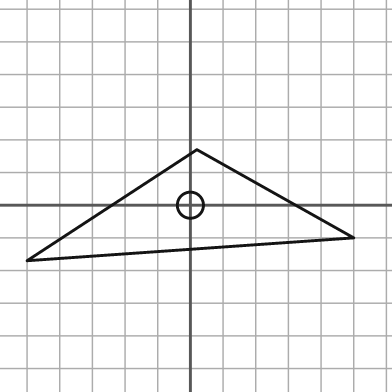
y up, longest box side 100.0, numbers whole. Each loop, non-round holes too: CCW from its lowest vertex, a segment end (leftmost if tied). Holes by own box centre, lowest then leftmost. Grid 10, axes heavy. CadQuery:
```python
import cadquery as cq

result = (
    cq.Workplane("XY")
    .moveTo(-50.0, -17.0)
    .lineTo(50.0, -10.0)
    .lineTo(2.0, 17.0)
    .close()
    .moveTo(0.0, 0.0)
    .circle(4.0)
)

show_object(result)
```